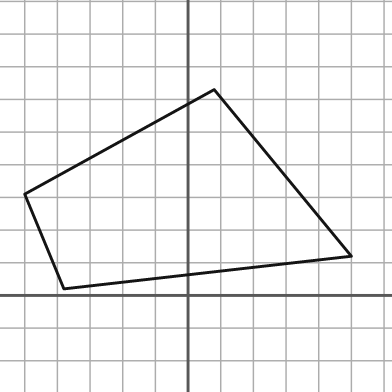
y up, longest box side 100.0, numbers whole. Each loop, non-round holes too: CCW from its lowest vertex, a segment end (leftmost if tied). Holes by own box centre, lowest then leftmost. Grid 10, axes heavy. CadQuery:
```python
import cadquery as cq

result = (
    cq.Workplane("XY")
    .moveTo(-38.0, 2.0)
    .lineTo(50.0, 12.0)
    .lineTo(8.0, 63.0)
    .lineTo(-50.0, 31.0)
    .close()
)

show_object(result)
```